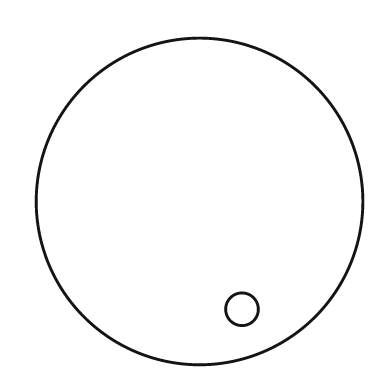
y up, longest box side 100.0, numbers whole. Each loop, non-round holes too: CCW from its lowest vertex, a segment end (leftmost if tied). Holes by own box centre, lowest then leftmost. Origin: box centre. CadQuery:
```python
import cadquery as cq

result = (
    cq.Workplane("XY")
    .moveTo(0.0, 0.0)
    .circle(50.0)
    .moveTo(13.0, -33.0)
    .circle(5.0)
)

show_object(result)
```